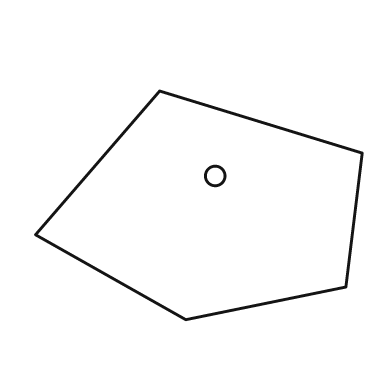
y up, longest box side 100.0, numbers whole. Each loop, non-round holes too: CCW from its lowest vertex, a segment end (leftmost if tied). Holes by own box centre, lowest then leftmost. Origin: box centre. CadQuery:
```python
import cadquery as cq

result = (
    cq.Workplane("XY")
    .moveTo(-4.0, -35.0)
    .lineTo(45.0, -25.0)
    .lineTo(50.0, 16.0)
    .lineTo(-12.0, 35.0)
    .lineTo(-50.0, -9.0)
    .close()
    .moveTo(5.0, 9.0)
    .circle(3.0)
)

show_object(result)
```